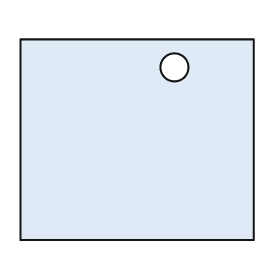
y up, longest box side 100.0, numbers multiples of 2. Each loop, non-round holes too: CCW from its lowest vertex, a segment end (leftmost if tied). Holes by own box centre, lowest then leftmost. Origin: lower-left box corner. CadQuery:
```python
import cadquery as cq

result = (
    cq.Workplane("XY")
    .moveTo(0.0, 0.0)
    .lineTo(100.0, 0.0)
    .lineTo(100.0, 86.0)
    .lineTo(0.0, 86.0)
    .close()
    .moveTo(66.0, 74.0)
    .circle(6.0)
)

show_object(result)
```